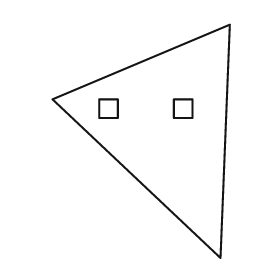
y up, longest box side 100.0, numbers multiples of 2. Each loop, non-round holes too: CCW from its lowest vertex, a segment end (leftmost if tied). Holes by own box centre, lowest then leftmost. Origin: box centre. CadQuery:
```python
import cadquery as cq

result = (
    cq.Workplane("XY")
    .moveTo(34.0, -50.0)
    .lineTo(38.0, 50.0)
    .lineTo(-38.0, 18.0)
    .close()
    .moveTo(-18.0, 10.0)
    .lineTo(-10.0, 10.0)
    .lineTo(-10.0, 18.0)
    .lineTo(-18.0, 18.0)
    .close()
    .moveTo(14.0, 10.0)
    .lineTo(22.0, 10.0)
    .lineTo(22.0, 18.0)
    .lineTo(14.0, 18.0)
    .close()
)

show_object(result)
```